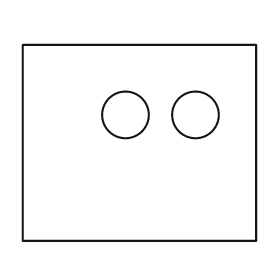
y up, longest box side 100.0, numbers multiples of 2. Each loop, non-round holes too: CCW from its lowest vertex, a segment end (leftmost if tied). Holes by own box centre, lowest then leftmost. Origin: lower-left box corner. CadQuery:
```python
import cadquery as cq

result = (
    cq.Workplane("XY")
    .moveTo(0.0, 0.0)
    .lineTo(100.0, 0.0)
    .lineTo(100.0, 84.0)
    .lineTo(0.0, 84.0)
    .close()
    .moveTo(44.0, 54.0)
    .circle(10.0)
    .moveTo(74.0, 54.0)
    .circle(10.0)
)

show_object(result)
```